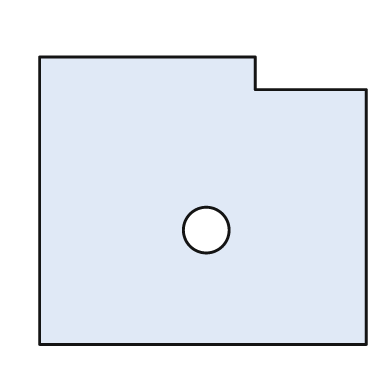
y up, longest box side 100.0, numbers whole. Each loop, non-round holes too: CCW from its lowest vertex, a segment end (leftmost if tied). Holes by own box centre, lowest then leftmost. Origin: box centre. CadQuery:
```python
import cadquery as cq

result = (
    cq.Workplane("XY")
    .moveTo(-50.0, -44.0)
    .lineTo(50.0, -44.0)
    .lineTo(50.0, 34.0)
    .lineTo(16.0, 34.0)
    .lineTo(16.0, 44.0)
    .lineTo(-50.0, 44.0)
    .close()
    .moveTo(1.0, -9.0)
    .circle(7.0)
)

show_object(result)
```